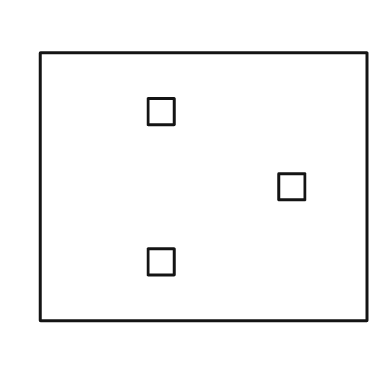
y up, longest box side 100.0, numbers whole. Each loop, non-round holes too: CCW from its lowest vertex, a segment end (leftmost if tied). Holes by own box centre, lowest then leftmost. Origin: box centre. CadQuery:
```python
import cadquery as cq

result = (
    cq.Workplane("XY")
    .moveTo(-50.0, -41.0)
    .lineTo(50.0, -41.0)
    .lineTo(50.0, 41.0)
    .lineTo(-50.0, 41.0)
    .close()
    .moveTo(-17.0, -27.0)
    .lineTo(-9.0, -27.0)
    .lineTo(-9.0, -19.0)
    .lineTo(-17.0, -19.0)
    .close()
    .moveTo(23.0, -4.0)
    .lineTo(31.0, -4.0)
    .lineTo(31.0, 4.0)
    .lineTo(23.0, 4.0)
    .close()
    .moveTo(-17.0, 19.0)
    .lineTo(-9.0, 19.0)
    .lineTo(-9.0, 27.0)
    .lineTo(-17.0, 27.0)
    .close()
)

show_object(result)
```